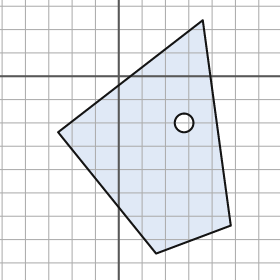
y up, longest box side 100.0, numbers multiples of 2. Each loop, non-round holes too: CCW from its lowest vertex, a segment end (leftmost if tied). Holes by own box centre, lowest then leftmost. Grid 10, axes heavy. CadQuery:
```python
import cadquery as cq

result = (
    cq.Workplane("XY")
    .moveTo(16.0, -76.0)
    .lineTo(48.0, -64.0)
    .lineTo(36.0, 24.0)
    .lineTo(-26.0, -24.0)
    .close()
    .moveTo(28.0, -20.0)
    .circle(4.0)
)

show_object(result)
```